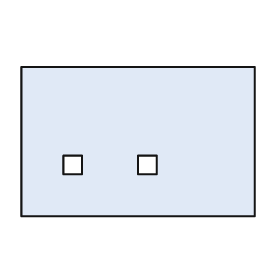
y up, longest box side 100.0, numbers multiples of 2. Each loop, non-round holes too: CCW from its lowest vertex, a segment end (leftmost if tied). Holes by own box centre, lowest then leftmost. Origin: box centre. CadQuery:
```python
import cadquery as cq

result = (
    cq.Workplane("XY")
    .moveTo(-50.0, -32.0)
    .lineTo(50.0, -32.0)
    .lineTo(50.0, 32.0)
    .lineTo(-50.0, 32.0)
    .close()
    .moveTo(-32.0, -14.0)
    .lineTo(-24.0, -14.0)
    .lineTo(-24.0, -6.0)
    .lineTo(-32.0, -6.0)
    .close()
    .moveTo(0.0, -14.0)
    .lineTo(8.0, -14.0)
    .lineTo(8.0, -6.0)
    .lineTo(0.0, -6.0)
    .close()
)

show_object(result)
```